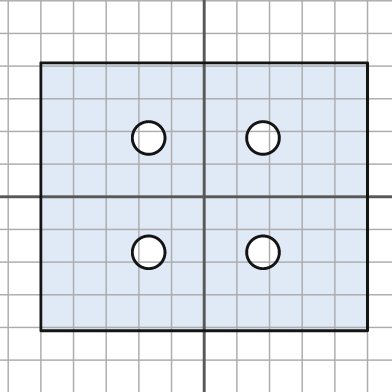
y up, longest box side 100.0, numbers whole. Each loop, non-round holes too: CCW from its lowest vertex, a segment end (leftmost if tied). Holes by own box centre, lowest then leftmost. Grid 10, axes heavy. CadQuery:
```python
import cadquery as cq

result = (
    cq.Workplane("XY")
    .moveTo(-50.0, -41.0)
    .lineTo(50.0, -41.0)
    .lineTo(50.0, 41.0)
    .lineTo(-50.0, 41.0)
    .close()
    .moveTo(-17.0, -17.0)
    .circle(5.0)
    .moveTo(18.0, -17.0)
    .circle(5.0)
    .moveTo(-17.0, 18.0)
    .circle(5.0)
    .moveTo(18.0, 18.0)
    .circle(5.0)
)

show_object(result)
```